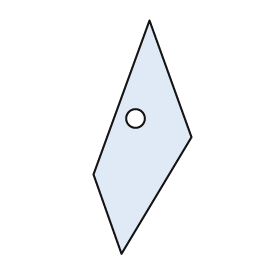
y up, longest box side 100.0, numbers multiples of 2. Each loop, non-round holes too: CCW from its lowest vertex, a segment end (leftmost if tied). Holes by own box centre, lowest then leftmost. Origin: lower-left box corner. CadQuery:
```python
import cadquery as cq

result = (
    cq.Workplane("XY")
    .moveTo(12.0, 0.0)
    .lineTo(42.0, 50.0)
    .lineTo(24.0, 100.0)
    .lineTo(0.0, 34.0)
    .close()
    .moveTo(18.0, 58.0)
    .circle(4.0)
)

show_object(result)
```